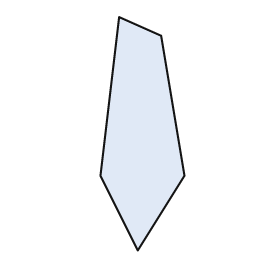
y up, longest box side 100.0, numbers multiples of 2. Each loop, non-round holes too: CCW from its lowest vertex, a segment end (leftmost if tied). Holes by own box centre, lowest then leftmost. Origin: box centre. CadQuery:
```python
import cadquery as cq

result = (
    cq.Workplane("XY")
    .moveTo(-2.0, -50.0)
    .lineTo(18.0, -18.0)
    .lineTo(8.0, 42.0)
    .lineTo(-10.0, 50.0)
    .lineTo(-18.0, -18.0)
    .close()
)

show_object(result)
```